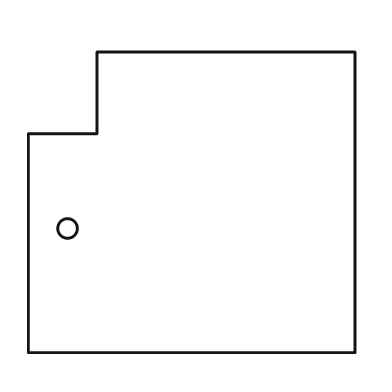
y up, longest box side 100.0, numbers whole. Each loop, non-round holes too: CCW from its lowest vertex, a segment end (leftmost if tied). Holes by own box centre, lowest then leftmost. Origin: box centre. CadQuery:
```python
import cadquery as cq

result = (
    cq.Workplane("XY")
    .moveTo(-50.0, -46.0)
    .lineTo(50.0, -46.0)
    .lineTo(50.0, 46.0)
    .lineTo(-29.0, 46.0)
    .lineTo(-29.0, 21.0)
    .lineTo(-50.0, 21.0)
    .close()
    .moveTo(-38.0, -8.0)
    .circle(3.0)
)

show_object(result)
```